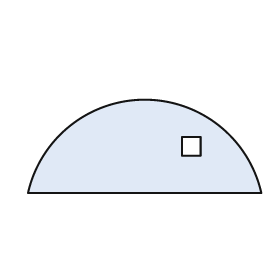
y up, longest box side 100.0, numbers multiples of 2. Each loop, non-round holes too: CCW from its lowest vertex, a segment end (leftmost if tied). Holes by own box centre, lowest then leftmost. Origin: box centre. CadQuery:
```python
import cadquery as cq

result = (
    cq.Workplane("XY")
    .moveTo(-50.0, -20.0)
    .lineTo(50.0, -20.0)
    .threePointArc((0.0, 20.0), (-50.0, -20.0))
    .close()
    .moveTo(16.0, -4.0)
    .lineTo(24.0, -4.0)
    .lineTo(24.0, 4.0)
    .lineTo(16.0, 4.0)
    .close()
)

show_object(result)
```